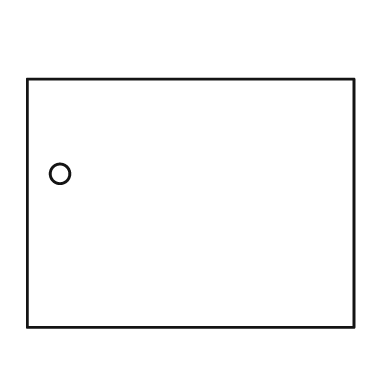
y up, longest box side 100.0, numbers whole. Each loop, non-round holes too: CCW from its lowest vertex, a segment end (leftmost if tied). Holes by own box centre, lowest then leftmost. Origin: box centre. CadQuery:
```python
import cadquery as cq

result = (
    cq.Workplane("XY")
    .moveTo(-50.0, -38.0)
    .lineTo(50.0, -38.0)
    .lineTo(50.0, 38.0)
    .lineTo(-50.0, 38.0)
    .close()
    .moveTo(-40.0, 9.0)
    .circle(3.0)
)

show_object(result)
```